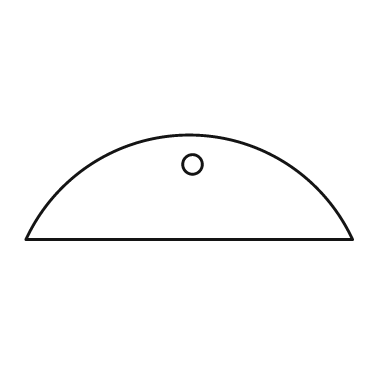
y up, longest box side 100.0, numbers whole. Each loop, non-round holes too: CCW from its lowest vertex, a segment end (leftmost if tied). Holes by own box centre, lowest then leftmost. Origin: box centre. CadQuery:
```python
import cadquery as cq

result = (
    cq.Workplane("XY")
    .moveTo(-50.0, -16.0)
    .lineTo(50.0, -16.0)
    .threePointArc((0.0, 16.0), (-50.0, -16.0))
    .close()
    .moveTo(1.0, 7.0)
    .circle(3.0)
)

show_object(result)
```